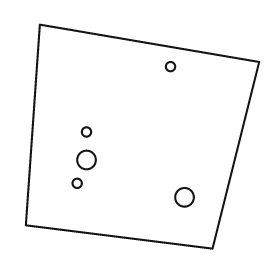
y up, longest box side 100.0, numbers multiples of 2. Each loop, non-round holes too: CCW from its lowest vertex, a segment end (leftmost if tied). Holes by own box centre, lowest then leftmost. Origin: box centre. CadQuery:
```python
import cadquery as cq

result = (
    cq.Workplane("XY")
    .moveTo(30.0, -48.0)
    .lineTo(50.0, 32.0)
    .lineTo(-44.0, 48.0)
    .lineTo(-50.0, -38.0)
    .close()
    .moveTo(18.0, -26.0)
    .circle(4.0)
    .moveTo(-28.0, -20.0)
    .circle(2.0)
    .moveTo(-24.0, -10.0)
    .circle(4.0)
    .moveTo(-24.0, 2.0)
    .circle(2.0)
    .moveTo(12.0, 30.0)
    .circle(2.0)
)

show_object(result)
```